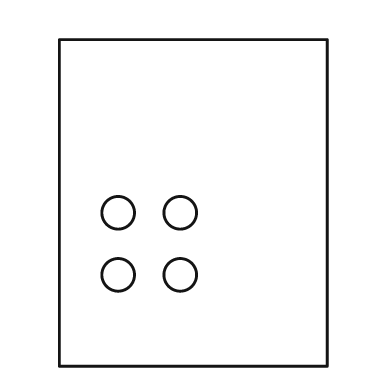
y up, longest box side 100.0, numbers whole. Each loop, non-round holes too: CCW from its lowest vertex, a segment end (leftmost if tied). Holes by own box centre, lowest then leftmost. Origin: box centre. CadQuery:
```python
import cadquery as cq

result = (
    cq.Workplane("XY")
    .moveTo(-41.0, -50.0)
    .lineTo(41.0, -50.0)
    .lineTo(41.0, 50.0)
    .lineTo(-41.0, 50.0)
    .close()
    .moveTo(-23.0, -22.0)
    .circle(5.0)
    .moveTo(-4.0, -22.0)
    .circle(5.0)
    .moveTo(-23.0, -3.0)
    .circle(5.0)
    .moveTo(-4.0, -3.0)
    .circle(5.0)
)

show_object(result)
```